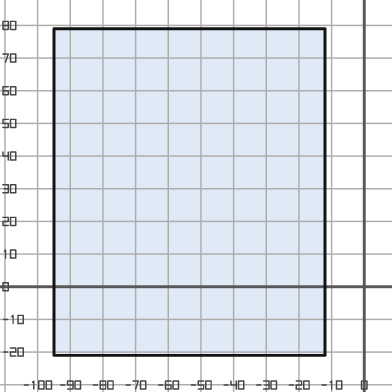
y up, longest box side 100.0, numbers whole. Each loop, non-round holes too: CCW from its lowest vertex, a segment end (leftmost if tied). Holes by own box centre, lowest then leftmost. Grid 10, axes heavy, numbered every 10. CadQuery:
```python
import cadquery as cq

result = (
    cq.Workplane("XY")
    .moveTo(-95.0, -21.0)
    .lineTo(-12.0, -21.0)
    .lineTo(-12.0, 79.0)
    .lineTo(-95.0, 79.0)
    .close()
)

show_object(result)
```